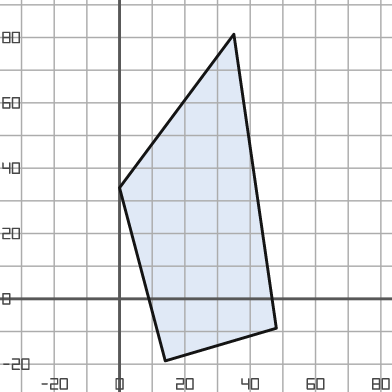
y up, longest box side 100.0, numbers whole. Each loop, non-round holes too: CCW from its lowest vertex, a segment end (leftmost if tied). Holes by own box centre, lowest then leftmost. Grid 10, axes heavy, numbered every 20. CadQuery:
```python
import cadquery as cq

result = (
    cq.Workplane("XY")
    .moveTo(14.0, -19.0)
    .lineTo(48.0, -9.0)
    .lineTo(35.0, 81.0)
    .lineTo(0.0, 34.0)
    .close()
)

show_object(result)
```